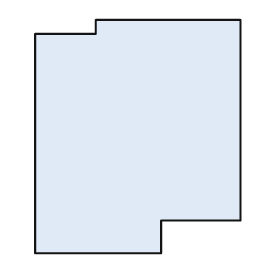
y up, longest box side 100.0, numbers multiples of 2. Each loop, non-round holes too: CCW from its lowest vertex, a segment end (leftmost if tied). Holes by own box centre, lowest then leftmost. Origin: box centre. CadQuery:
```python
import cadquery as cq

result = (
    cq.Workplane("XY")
    .moveTo(-44.0, -50.0)
    .lineTo(10.0, -50.0)
    .lineTo(10.0, -36.0)
    .lineTo(44.0, -36.0)
    .lineTo(44.0, 50.0)
    .lineTo(-18.0, 50.0)
    .lineTo(-18.0, 44.0)
    .lineTo(-44.0, 44.0)
    .close()
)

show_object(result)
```